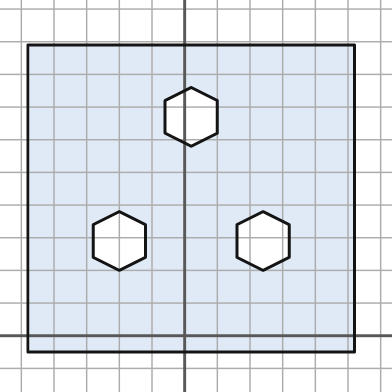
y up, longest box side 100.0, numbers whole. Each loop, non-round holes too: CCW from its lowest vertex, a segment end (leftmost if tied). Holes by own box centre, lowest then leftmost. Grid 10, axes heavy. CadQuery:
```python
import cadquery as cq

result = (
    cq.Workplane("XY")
    .moveTo(-48.0, -5.0)
    .lineTo(52.0, -5.0)
    .lineTo(52.0, 89.0)
    .lineTo(-48.0, 89.0)
    .close()
    .moveTo(-20.0, 20.0)
    .lineTo(-12.0, 24.0)
    .lineTo(-12.0, 34.0)
    .lineTo(-20.0, 38.0)
    .lineTo(-28.0, 34.0)
    .lineTo(-28.0, 24.0)
    .close()
    .moveTo(24.0, 20.0)
    .lineTo(32.0, 24.0)
    .lineTo(32.0, 34.0)
    .lineTo(24.0, 38.0)
    .lineTo(16.0, 34.0)
    .lineTo(16.0, 24.0)
    .close()
    .moveTo(2.0, 58.0)
    .lineTo(10.0, 62.0)
    .lineTo(10.0, 72.0)
    .lineTo(2.0, 76.0)
    .lineTo(-6.0, 72.0)
    .lineTo(-6.0, 62.0)
    .close()
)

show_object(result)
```